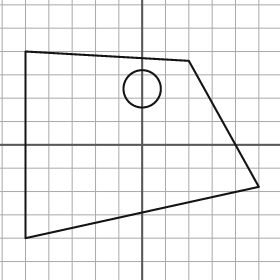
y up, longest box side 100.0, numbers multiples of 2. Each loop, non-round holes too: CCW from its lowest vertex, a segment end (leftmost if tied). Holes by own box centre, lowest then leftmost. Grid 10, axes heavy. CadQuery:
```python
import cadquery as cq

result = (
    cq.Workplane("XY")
    .moveTo(-50.0, -40.0)
    .lineTo(50.0, -18.0)
    .lineTo(20.0, 36.0)
    .lineTo(-50.0, 40.0)
    .close()
    .moveTo(0.0, 24.0)
    .circle(8.0)
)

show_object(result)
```